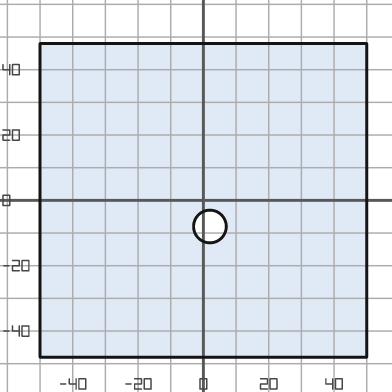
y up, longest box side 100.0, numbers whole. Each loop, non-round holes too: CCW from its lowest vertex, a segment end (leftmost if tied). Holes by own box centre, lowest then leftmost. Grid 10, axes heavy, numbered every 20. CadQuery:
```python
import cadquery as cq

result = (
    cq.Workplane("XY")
    .moveTo(-50.0, -48.0)
    .lineTo(50.0, -48.0)
    .lineTo(50.0, 48.0)
    .lineTo(-50.0, 48.0)
    .close()
    .moveTo(2.0, -8.0)
    .circle(5.0)
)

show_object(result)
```